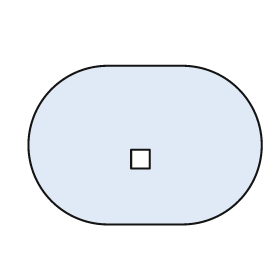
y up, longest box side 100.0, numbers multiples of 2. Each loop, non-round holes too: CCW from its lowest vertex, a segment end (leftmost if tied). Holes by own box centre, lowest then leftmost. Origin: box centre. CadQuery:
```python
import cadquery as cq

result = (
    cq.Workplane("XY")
    .moveTo(-16.0, -34.0)
    .lineTo(16.0, -34.0)
    .threePointArc((50.0, 0.0), (16.0, 34.0))
    .lineTo(-16.0, 34.0)
    .threePointArc((-50.0, 0.0), (-16.0, -34.0))
    .close()
    .moveTo(-6.0, -10.0)
    .lineTo(2.0, -10.0)
    .lineTo(2.0, -2.0)
    .lineTo(-6.0, -2.0)
    .close()
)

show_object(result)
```